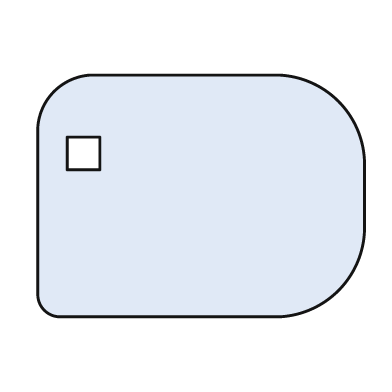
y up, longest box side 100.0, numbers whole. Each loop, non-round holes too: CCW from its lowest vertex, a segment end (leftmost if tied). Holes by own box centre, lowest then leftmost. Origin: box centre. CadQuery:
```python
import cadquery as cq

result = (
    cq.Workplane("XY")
    .moveTo(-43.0, -37.0)
    .lineTo(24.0, -37.0)
    .threePointArc((42.0, -29.0), (50.0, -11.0))
    .lineTo(50.0, 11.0)
    .threePointArc((42.0, 29.0), (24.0, 37.0))
    .lineTo(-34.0, 37.0)
    .threePointArc((-45.0, 32.0), (-50.0, 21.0))
    .lineTo(-50.0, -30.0)
    .threePointArc((-48.0, -35.0), (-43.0, -37.0))
    .close()
    .moveTo(-41.0, 8.0)
    .lineTo(-31.0, 8.0)
    .lineTo(-31.0, 18.0)
    .lineTo(-41.0, 18.0)
    .close()
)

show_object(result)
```